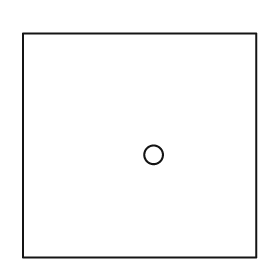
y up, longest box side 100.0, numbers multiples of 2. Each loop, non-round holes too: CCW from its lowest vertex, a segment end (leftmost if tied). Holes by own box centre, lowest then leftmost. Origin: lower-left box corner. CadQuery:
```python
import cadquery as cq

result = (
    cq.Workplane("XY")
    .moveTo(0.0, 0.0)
    .lineTo(100.0, 0.0)
    .lineTo(100.0, 96.0)
    .lineTo(0.0, 96.0)
    .close()
    .moveTo(56.0, 44.0)
    .circle(4.0)
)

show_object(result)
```